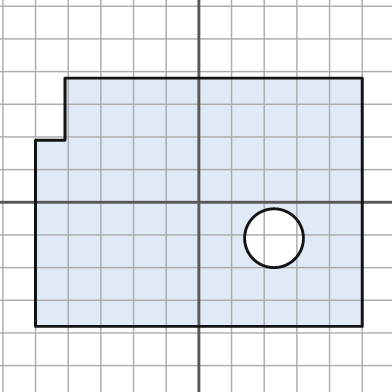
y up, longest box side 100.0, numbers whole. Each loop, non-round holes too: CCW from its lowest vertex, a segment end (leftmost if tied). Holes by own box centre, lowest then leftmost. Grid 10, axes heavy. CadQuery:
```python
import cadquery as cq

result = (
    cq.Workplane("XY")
    .moveTo(-50.0, -38.0)
    .lineTo(50.0, -38.0)
    .lineTo(50.0, 38.0)
    .lineTo(-41.0, 38.0)
    .lineTo(-41.0, 19.0)
    .lineTo(-50.0, 19.0)
    .close()
    .moveTo(23.0, -11.0)
    .circle(9.0)
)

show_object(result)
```